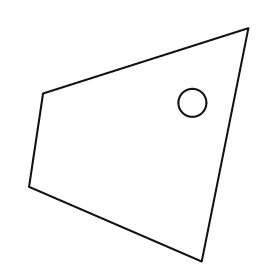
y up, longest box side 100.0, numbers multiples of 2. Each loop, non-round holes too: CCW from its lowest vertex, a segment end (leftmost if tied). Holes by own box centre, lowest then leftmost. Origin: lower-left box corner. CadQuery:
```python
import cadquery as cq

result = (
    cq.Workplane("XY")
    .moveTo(74.0, 0.0)
    .lineTo(94.0, 100.0)
    .lineTo(6.0, 72.0)
    .lineTo(0.0, 32.0)
    .close()
    .moveTo(70.0, 68.0)
    .circle(6.0)
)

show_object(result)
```